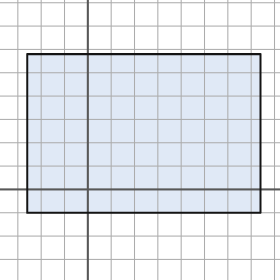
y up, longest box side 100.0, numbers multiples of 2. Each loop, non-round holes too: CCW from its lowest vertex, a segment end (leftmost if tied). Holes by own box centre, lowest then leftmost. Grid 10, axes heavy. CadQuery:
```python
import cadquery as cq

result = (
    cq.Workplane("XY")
    .moveTo(-26.0, -10.0)
    .lineTo(74.0, -10.0)
    .lineTo(74.0, 58.0)
    .lineTo(-26.0, 58.0)
    .close()
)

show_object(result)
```